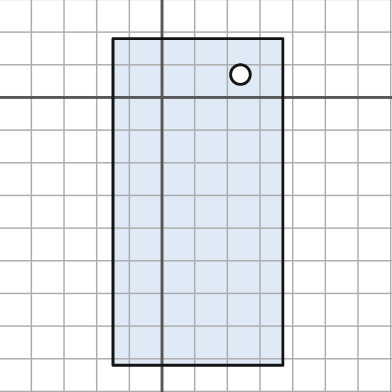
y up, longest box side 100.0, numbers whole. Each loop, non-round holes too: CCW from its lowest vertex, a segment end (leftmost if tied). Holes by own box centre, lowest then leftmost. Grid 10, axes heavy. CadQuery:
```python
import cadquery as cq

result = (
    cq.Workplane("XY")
    .moveTo(-15.0, -82.0)
    .lineTo(37.0, -82.0)
    .lineTo(37.0, 18.0)
    .lineTo(-15.0, 18.0)
    .close()
    .moveTo(24.0, 7.0)
    .circle(3.0)
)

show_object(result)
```